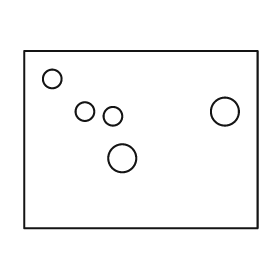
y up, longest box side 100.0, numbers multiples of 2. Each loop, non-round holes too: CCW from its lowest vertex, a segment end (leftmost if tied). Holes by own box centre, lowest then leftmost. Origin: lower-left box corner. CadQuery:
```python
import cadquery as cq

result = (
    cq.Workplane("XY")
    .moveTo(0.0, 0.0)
    .lineTo(100.0, 0.0)
    .lineTo(100.0, 76.0)
    .lineTo(0.0, 76.0)
    .close()
    .moveTo(42.0, 30.0)
    .circle(6.0)
    .moveTo(38.0, 48.0)
    .circle(4.0)
    .moveTo(26.0, 50.0)
    .circle(4.0)
    .moveTo(86.0, 50.0)
    .circle(6.0)
    .moveTo(12.0, 64.0)
    .circle(4.0)
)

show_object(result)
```